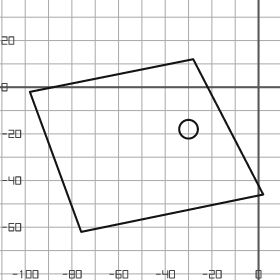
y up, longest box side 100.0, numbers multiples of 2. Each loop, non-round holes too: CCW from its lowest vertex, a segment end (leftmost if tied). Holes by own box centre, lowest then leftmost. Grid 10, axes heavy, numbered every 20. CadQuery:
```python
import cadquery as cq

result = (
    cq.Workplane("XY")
    .moveTo(-76.0, -62.0)
    .lineTo(2.0, -46.0)
    .lineTo(-28.0, 12.0)
    .lineTo(-98.0, -2.0)
    .close()
    .moveTo(-30.0, -18.0)
    .circle(4.0)
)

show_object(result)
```